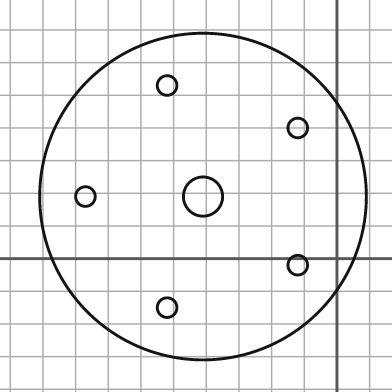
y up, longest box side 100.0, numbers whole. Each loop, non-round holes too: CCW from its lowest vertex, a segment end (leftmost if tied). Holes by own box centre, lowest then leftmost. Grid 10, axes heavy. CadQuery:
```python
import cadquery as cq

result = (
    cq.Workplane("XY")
    .moveTo(-41.0, 19.0)
    .circle(50.0)
    .moveTo(-52.0, -15.0)
    .circle(3.0)
    .moveTo(-12.0, -2.0)
    .circle(3.0)
    .moveTo(-77.0, 19.0)
    .circle(3.0)
    .moveTo(-41.0, 19.0)
    .circle(6.0)
    .moveTo(-12.0, 40.0)
    .circle(3.0)
    .moveTo(-52.0, 53.0)
    .circle(3.0)
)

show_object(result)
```